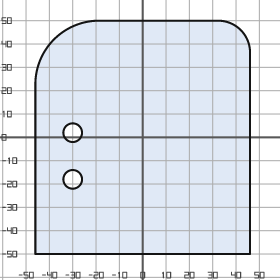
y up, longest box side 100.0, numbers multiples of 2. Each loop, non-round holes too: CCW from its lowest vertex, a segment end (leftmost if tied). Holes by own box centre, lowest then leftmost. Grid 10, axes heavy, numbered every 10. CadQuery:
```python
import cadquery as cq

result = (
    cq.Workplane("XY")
    .moveTo(-46.0, -50.0)
    .lineTo(46.0, -50.0)
    .lineTo(46.0, 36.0)
    .threePointArc((42.0, 46.0), (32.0, 50.0))
    .lineTo(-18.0, 50.0)
    .threePointArc((-38.0, 42.0), (-46.0, 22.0))
    .close()
    .moveTo(-30.0, -18.0)
    .circle(4.0)
    .moveTo(-30.0, 2.0)
    .circle(4.0)
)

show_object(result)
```